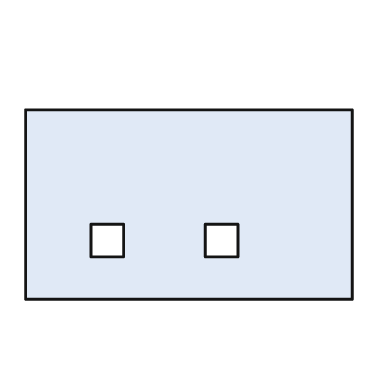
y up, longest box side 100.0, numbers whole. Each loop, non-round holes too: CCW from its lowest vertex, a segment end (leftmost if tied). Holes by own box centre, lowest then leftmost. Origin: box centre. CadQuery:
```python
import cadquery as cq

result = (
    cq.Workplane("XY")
    .moveTo(-50.0, -29.0)
    .lineTo(50.0, -29.0)
    .lineTo(50.0, 29.0)
    .lineTo(-50.0, 29.0)
    .close()
    .moveTo(-30.0, -16.0)
    .lineTo(-20.0, -16.0)
    .lineTo(-20.0, -6.0)
    .lineTo(-30.0, -6.0)
    .close()
    .moveTo(5.0, -16.0)
    .lineTo(15.0, -16.0)
    .lineTo(15.0, -6.0)
    .lineTo(5.0, -6.0)
    .close()
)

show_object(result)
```